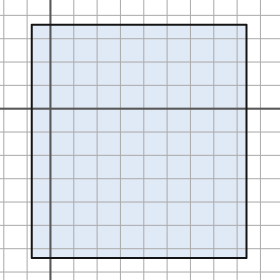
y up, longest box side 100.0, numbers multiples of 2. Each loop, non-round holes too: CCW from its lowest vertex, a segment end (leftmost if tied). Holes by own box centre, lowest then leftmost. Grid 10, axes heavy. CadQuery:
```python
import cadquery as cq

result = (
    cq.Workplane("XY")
    .moveTo(-8.0, -64.0)
    .lineTo(84.0, -64.0)
    .lineTo(84.0, 36.0)
    .lineTo(-8.0, 36.0)
    .close()
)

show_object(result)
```